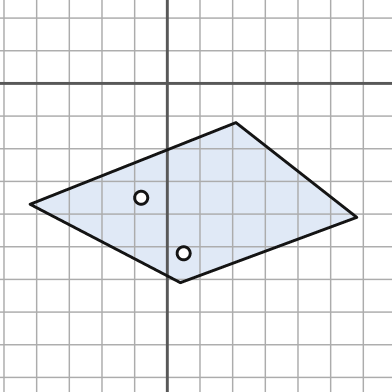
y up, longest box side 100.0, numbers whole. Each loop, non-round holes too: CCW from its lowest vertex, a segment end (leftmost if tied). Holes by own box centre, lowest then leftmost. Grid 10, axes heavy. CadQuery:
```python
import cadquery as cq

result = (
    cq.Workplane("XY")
    .moveTo(4.0, -61.0)
    .lineTo(58.0, -41.0)
    .lineTo(21.0, -12.0)
    .lineTo(-42.0, -37.0)
    .close()
    .moveTo(5.0, -52.0)
    .circle(2.0)
    .moveTo(-8.0, -35.0)
    .circle(2.0)
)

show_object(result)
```